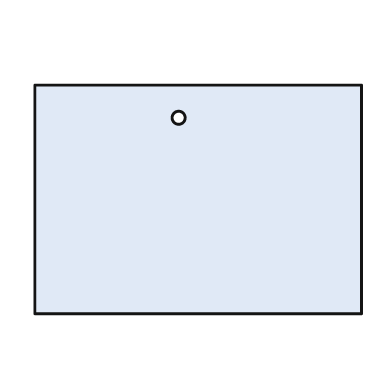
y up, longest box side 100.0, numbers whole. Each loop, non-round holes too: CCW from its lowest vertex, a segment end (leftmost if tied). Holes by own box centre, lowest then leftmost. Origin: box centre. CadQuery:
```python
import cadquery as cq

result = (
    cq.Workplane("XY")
    .moveTo(-50.0, -35.0)
    .lineTo(50.0, -35.0)
    .lineTo(50.0, 35.0)
    .lineTo(-50.0, 35.0)
    .close()
    .moveTo(-6.0, 25.0)
    .circle(2.0)
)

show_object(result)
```